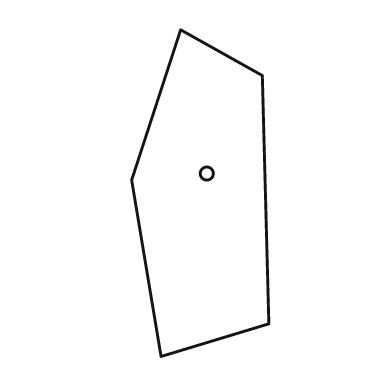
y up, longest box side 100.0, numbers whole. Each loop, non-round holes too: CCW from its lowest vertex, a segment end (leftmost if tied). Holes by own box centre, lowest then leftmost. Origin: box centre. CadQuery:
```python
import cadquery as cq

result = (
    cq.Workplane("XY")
    .moveTo(-12.0, -50.0)
    .lineTo(21.0, -40.0)
    .lineTo(19.0, 36.0)
    .lineTo(-6.0, 50.0)
    .lineTo(-21.0, 4.0)
    .close()
    .moveTo(2.0, 6.0)
    .circle(2.0)
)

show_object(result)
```